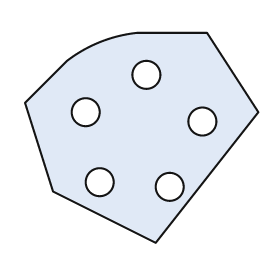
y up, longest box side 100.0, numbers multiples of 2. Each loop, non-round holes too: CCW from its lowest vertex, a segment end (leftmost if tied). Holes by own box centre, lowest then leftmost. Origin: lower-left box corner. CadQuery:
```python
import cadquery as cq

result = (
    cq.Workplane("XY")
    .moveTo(56.0, 0.0)
    .lineTo(100.0, 56.0)
    .lineTo(78.0, 90.0)
    .lineTo(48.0, 90.0)
    .threePointArc((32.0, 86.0), (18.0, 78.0))
    .lineTo(0.0, 60.0)
    .lineTo(12.0, 22.0)
    .close()
    .moveTo(62.0, 24.0)
    .circle(6.0)
    .moveTo(32.0, 26.0)
    .circle(6.0)
    .moveTo(76.0, 52.0)
    .circle(6.0)
    .moveTo(26.0, 56.0)
    .circle(6.0)
    .moveTo(52.0, 72.0)
    .circle(6.0)
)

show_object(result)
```